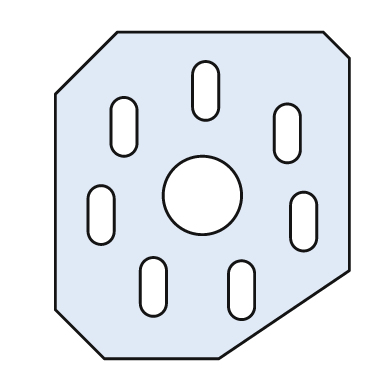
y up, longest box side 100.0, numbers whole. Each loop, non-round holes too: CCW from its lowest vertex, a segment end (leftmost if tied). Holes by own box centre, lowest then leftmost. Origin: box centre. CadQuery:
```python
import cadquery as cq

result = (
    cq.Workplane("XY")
    .moveTo(-30.0, -50.0)
    .lineTo(5.0, -50.0)
    .lineTo(45.0, -23.0)
    .lineTo(45.0, 42.0)
    .lineTo(37.0, 50.0)
    .lineTo(-26.0, 50.0)
    .lineTo(-45.0, 31.0)
    .lineTo(-45.0, -35.0)
    .close()
    .moveTo(8.0, -34.0)
    .threePointArc((12.0, -38.0), (16.0, -34.0))
    .lineTo(16.0, -24.0)
    .threePointArc((12.0, -20.0), (8.0, -24.0))
    .close()
    .moveTo(-19.0, -33.0)
    .threePointArc((-15.0, -37.0), (-11.0, -33.0))
    .lineTo(-11.0, -23.0)
    .threePointArc((-15.0, -19.0), (-19.0, -23.0))
    .close()
    .moveTo(27.0, -13.0)
    .threePointArc((31.0, -17.0), (35.0, -13.0))
    .lineTo(35.0, -3.0)
    .threePointArc((31.0, 1.0), (27.0, -3.0))
    .close()
    .moveTo(-35.0, -11.0)
    .threePointArc((-31.0, -15.0), (-27.0, -11.0))
    .lineTo(-27.0, -1.0)
    .threePointArc((-31.0, 3.0), (-35.0, -1.0))
    .close()
    .moveTo(0.0, 0.0)
    .circle(12.0)
    .moveTo(22.0, 14.0)
    .threePointArc((26.0, 10.0), (30.0, 14.0))
    .lineTo(30.0, 24.0)
    .threePointArc((26.0, 28.0), (22.0, 24.0))
    .close()
    .moveTo(-28.0, 16.0)
    .threePointArc((-24.0, 12.0), (-20.0, 16.0))
    .lineTo(-20.0, 26.0)
    .threePointArc((-24.0, 30.0), (-28.0, 26.0))
    .close()
    .moveTo(-3.0, 27.0)
    .threePointArc((1.0, 23.0), (5.0, 27.0))
    .lineTo(5.0, 37.0)
    .threePointArc((1.0, 41.0), (-3.0, 37.0))
    .close()
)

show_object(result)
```